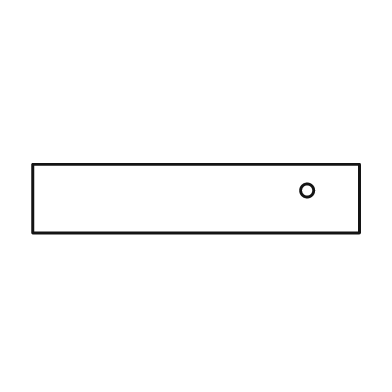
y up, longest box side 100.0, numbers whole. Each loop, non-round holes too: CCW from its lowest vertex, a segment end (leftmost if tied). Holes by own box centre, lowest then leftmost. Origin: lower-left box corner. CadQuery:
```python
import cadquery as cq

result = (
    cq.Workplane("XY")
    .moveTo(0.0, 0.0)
    .lineTo(100.0, 0.0)
    .lineTo(100.0, 21.0)
    .lineTo(0.0, 21.0)
    .close()
    .moveTo(84.0, 13.0)
    .circle(2.0)
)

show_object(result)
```